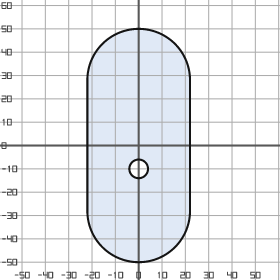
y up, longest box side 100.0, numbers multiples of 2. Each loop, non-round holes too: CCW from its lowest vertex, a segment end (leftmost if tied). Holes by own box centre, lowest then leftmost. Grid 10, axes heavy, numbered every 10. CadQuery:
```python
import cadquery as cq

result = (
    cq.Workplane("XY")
    .moveTo(-22.0, -28.0)
    .threePointArc((0.0, -50.0), (22.0, -28.0))
    .lineTo(22.0, 28.0)
    .threePointArc((0.0, 50.0), (-22.0, 28.0))
    .close()
    .moveTo(0.0, -10.0)
    .circle(4.0)
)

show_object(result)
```